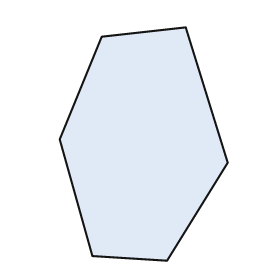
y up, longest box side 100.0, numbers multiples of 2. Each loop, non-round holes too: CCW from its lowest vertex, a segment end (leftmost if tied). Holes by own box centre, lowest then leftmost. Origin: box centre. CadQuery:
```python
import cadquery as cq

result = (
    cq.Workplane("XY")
    .moveTo(10.0, -50.0)
    .lineTo(36.0, -8.0)
    .lineTo(18.0, 50.0)
    .lineTo(-18.0, 46.0)
    .lineTo(-36.0, 2.0)
    .lineTo(-22.0, -48.0)
    .close()
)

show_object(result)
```